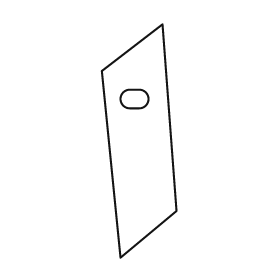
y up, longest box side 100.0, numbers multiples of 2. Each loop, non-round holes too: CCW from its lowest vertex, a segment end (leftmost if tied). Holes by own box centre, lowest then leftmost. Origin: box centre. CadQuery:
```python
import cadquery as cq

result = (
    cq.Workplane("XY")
    .moveTo(-8.0, -50.0)
    .lineTo(16.0, -30.0)
    .lineTo(10.0, 50.0)
    .lineTo(-16.0, 30.0)
    .close()
    .moveTo(-4.0, 14.0)
    .lineTo(0.0, 14.0)
    .threePointArc((4.0, 18.0), (0.0, 22.0))
    .lineTo(-4.0, 22.0)
    .threePointArc((-8.0, 18.0), (-4.0, 14.0))
    .close()
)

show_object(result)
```